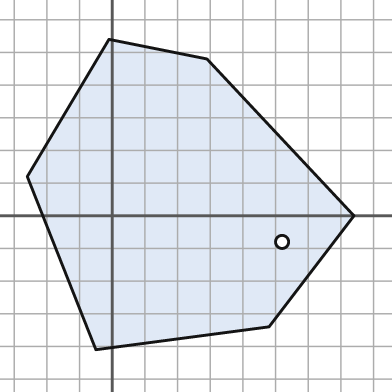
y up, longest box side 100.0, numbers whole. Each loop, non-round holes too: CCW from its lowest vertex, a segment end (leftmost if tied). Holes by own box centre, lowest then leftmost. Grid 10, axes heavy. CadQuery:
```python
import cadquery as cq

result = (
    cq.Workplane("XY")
    .moveTo(-5.0, -41.0)
    .lineTo(48.0, -34.0)
    .lineTo(74.0, 0.0)
    .lineTo(29.0, 48.0)
    .lineTo(-1.0, 54.0)
    .lineTo(-26.0, 12.0)
    .close()
    .moveTo(52.0, -8.0)
    .circle(2.0)
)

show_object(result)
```